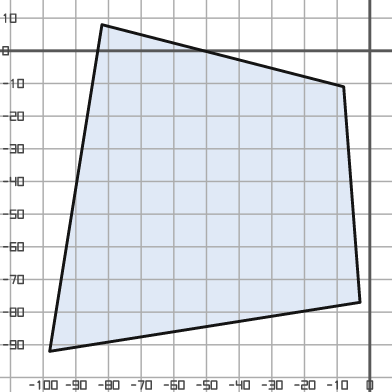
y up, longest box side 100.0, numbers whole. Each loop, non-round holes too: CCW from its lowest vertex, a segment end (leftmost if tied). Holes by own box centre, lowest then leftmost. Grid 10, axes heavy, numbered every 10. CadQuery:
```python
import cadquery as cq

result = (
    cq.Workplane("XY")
    .moveTo(-98.0, -92.0)
    .lineTo(-3.0, -77.0)
    .lineTo(-8.0, -11.0)
    .lineTo(-82.0, 8.0)
    .close()
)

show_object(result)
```